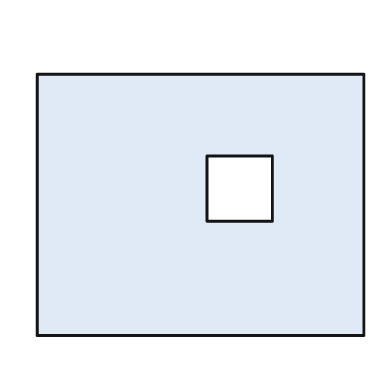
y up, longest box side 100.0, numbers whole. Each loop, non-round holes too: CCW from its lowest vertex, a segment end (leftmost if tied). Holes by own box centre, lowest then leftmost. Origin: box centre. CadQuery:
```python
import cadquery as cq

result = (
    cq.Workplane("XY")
    .moveTo(-50.0, -40.0)
    .lineTo(50.0, -40.0)
    .lineTo(50.0, 40.0)
    .lineTo(-50.0, 40.0)
    .close()
    .moveTo(2.0, -5.0)
    .lineTo(22.0, -5.0)
    .lineTo(22.0, 15.0)
    .lineTo(2.0, 15.0)
    .close()
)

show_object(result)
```